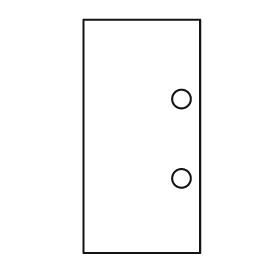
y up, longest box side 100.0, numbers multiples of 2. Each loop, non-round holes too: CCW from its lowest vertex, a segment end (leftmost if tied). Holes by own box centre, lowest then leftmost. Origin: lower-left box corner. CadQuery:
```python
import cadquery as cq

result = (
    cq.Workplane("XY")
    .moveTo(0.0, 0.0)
    .lineTo(50.0, 0.0)
    .lineTo(50.0, 100.0)
    .lineTo(0.0, 100.0)
    .close()
    .moveTo(42.0, 32.0)
    .circle(4.0)
    .moveTo(42.0, 66.0)
    .circle(4.0)
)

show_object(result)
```